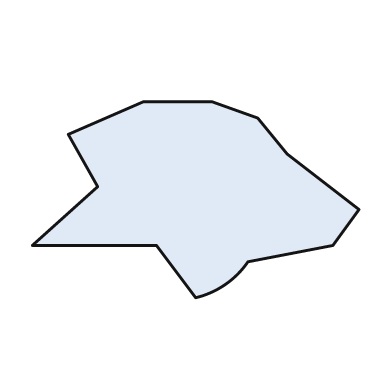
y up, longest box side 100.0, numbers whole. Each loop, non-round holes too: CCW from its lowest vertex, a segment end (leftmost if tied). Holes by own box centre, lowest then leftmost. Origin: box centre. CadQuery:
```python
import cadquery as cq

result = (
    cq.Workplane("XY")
    .moveTo(0.0, -30.0)
    .threePointArc((9.0, -26.0), (16.0, -19.0))
    .lineTo(42.0, -14.0)
    .lineTo(50.0, -3.0)
    .lineTo(28.0, 14.0)
    .lineTo(19.0, 25.0)
    .lineTo(5.0, 30.0)
    .lineTo(-16.0, 30.0)
    .lineTo(-39.0, 20.0)
    .lineTo(-30.0, 4.0)
    .lineTo(-50.0, -14.0)
    .lineTo(-12.0, -14.0)
    .close()
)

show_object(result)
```